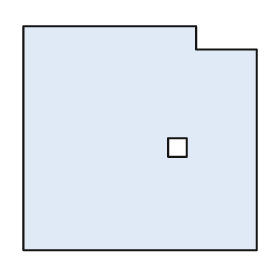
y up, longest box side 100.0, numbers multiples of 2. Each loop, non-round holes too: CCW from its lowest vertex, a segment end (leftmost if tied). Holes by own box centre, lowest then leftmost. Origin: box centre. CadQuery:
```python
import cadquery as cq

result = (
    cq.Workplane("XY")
    .moveTo(-50.0, -48.0)
    .lineTo(50.0, -48.0)
    .lineTo(50.0, 38.0)
    .lineTo(24.0, 38.0)
    .lineTo(24.0, 48.0)
    .lineTo(-50.0, 48.0)
    .close()
    .moveTo(12.0, -8.0)
    .lineTo(20.0, -8.0)
    .lineTo(20.0, 0.0)
    .lineTo(12.0, 0.0)
    .close()
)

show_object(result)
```